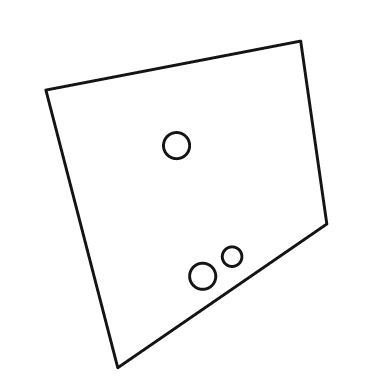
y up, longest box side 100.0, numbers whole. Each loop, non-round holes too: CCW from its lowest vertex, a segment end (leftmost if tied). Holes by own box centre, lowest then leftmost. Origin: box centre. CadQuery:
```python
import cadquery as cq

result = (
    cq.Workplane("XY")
    .moveTo(-21.0, -50.0)
    .lineTo(43.0, -6.0)
    .lineTo(35.0, 50.0)
    .lineTo(-43.0, 35.0)
    .close()
    .moveTo(5.0, -22.0)
    .circle(4.0)
    .moveTo(14.0, -16.0)
    .circle(3.0)
    .moveTo(-3.0, 18.0)
    .circle(4.0)
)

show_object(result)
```